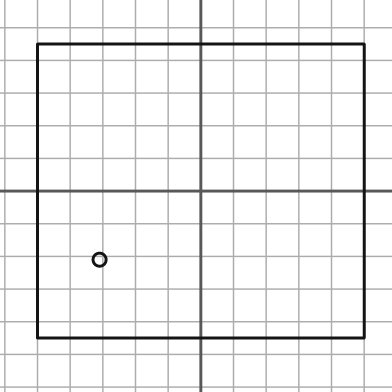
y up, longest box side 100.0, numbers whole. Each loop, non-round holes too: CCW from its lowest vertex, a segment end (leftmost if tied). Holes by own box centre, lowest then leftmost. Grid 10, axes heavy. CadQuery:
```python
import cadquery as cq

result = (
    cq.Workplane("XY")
    .moveTo(-50.0, -45.0)
    .lineTo(50.0, -45.0)
    .lineTo(50.0, 45.0)
    .lineTo(-50.0, 45.0)
    .close()
    .moveTo(-31.0, -21.0)
    .circle(2.0)
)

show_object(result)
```